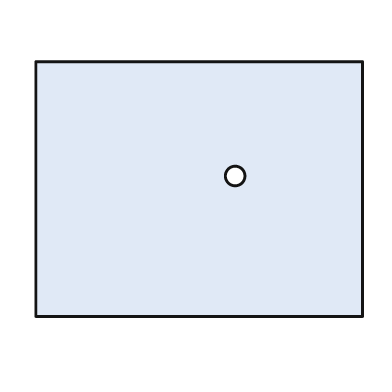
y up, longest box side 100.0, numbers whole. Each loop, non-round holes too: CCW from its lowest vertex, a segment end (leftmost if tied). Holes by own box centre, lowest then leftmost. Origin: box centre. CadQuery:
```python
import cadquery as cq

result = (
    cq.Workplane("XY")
    .moveTo(-50.0, -39.0)
    .lineTo(50.0, -39.0)
    .lineTo(50.0, 39.0)
    .lineTo(-50.0, 39.0)
    .close()
    .moveTo(11.0, 4.0)
    .circle(3.0)
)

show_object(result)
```